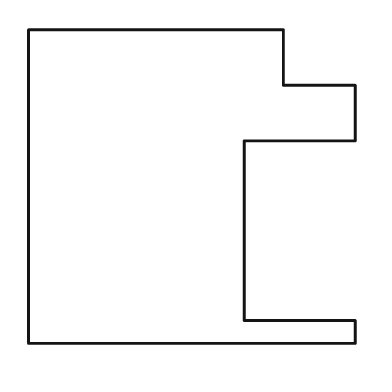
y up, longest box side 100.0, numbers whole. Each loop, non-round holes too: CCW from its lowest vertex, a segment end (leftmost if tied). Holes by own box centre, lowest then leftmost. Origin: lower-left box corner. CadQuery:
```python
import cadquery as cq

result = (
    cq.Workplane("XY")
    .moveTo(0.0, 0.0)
    .lineTo(100.0, 0.0)
    .lineTo(100.0, 7.0)
    .lineTo(66.0, 7.0)
    .lineTo(66.0, 62.0)
    .lineTo(100.0, 62.0)
    .lineTo(100.0, 79.0)
    .lineTo(78.0, 79.0)
    .lineTo(78.0, 96.0)
    .lineTo(0.0, 96.0)
    .close()
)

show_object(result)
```